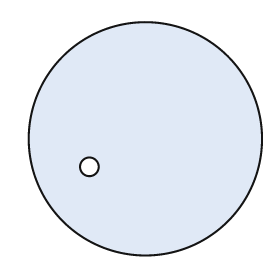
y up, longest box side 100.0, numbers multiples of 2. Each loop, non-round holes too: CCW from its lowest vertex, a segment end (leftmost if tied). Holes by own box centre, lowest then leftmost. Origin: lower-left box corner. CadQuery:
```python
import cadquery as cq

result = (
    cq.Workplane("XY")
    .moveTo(50.0, 50.0)
    .circle(50.0)
    .moveTo(26.0, 38.0)
    .circle(4.0)
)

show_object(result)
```